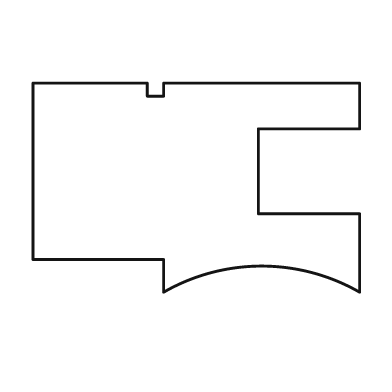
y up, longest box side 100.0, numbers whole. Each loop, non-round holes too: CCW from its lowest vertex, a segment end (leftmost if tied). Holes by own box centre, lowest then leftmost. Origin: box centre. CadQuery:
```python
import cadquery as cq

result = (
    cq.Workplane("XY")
    .moveTo(-10.0, -32.0)
    .threePointArc((20.0, -24.0), (50.0, -32.0))
    .lineTo(50.0, -8.0)
    .lineTo(19.0, -8.0)
    .lineTo(19.0, 18.0)
    .lineTo(50.0, 18.0)
    .lineTo(50.0, 32.0)
    .lineTo(-10.0, 32.0)
    .lineTo(-10.0, 28.0)
    .lineTo(-15.0, 28.0)
    .lineTo(-15.0, 32.0)
    .lineTo(-50.0, 32.0)
    .lineTo(-50.0, -22.0)
    .lineTo(-10.0, -22.0)
    .close()
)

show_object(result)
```